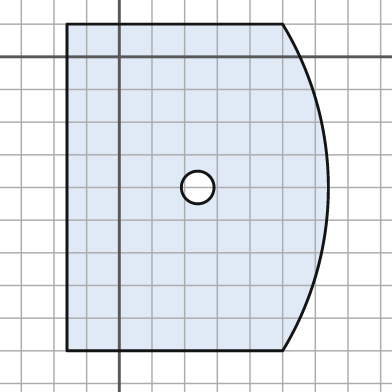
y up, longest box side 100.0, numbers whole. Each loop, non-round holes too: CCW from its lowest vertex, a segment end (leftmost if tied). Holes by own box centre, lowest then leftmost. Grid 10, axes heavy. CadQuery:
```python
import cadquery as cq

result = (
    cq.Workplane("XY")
    .moveTo(-16.0, -90.0)
    .lineTo(50.0, -90.0)
    .threePointArc((64.0, -40.0), (50.0, 10.0))
    .lineTo(-16.0, 10.0)
    .close()
    .moveTo(24.0, -40.0)
    .circle(5.0)
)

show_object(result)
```